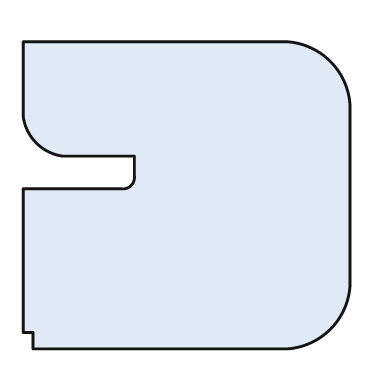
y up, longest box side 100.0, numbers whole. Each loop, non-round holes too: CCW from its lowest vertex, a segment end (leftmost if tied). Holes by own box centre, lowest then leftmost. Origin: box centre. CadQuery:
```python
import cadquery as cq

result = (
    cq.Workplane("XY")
    .moveTo(-47.0, -47.0)
    .lineTo(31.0, -47.0)
    .threePointArc((44.0, -41.0), (50.0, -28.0))
    .lineTo(50.0, 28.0)
    .threePointArc((44.0, 41.0), (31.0, 47.0))
    .lineTo(-50.0, 47.0)
    .lineTo(-50.0, 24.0)
    .threePointArc((-46.0, 16.0), (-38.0, 12.0))
    .lineTo(-16.0, 12.0)
    .lineTo(-16.0, 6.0)
    .threePointArc((-17.0, 3.0), (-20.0, 2.0))
    .lineTo(-50.0, 2.0)
    .lineTo(-50.0, -42.0)
    .lineTo(-47.0, -42.0)
    .close()
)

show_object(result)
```